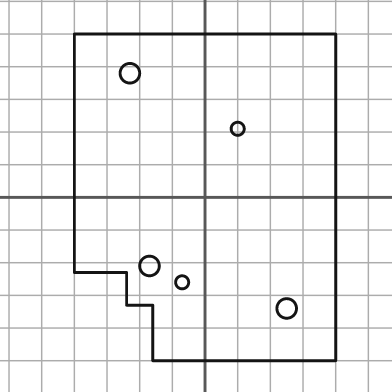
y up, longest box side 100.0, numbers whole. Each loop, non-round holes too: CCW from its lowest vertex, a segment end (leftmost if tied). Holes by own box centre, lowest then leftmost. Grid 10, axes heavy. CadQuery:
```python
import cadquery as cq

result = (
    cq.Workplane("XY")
    .moveTo(-16.0, -50.0)
    .lineTo(40.0, -50.0)
    .lineTo(40.0, 50.0)
    .lineTo(-40.0, 50.0)
    .lineTo(-40.0, -23.0)
    .lineTo(-24.0, -23.0)
    .lineTo(-24.0, -33.0)
    .lineTo(-16.0, -33.0)
    .close()
    .moveTo(25.0, -34.0)
    .circle(3.0)
    .moveTo(-7.0, -26.0)
    .circle(2.0)
    .moveTo(-17.0, -21.0)
    .circle(3.0)
    .moveTo(10.0, 21.0)
    .circle(2.0)
    .moveTo(-23.0, 38.0)
    .circle(3.0)
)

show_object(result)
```